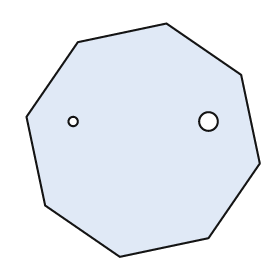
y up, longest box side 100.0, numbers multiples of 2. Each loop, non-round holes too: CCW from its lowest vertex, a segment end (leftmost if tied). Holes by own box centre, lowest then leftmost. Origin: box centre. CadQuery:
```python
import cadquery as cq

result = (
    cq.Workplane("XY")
    .moveTo(-10.0, -50.0)
    .lineTo(28.0, -42.0)
    .lineTo(50.0, -10.0)
    .lineTo(42.0, 28.0)
    .lineTo(10.0, 50.0)
    .lineTo(-28.0, 42.0)
    .lineTo(-50.0, 10.0)
    .lineTo(-42.0, -28.0)
    .close()
    .moveTo(-30.0, 8.0)
    .circle(2.0)
    .moveTo(28.0, 8.0)
    .circle(4.0)
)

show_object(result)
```